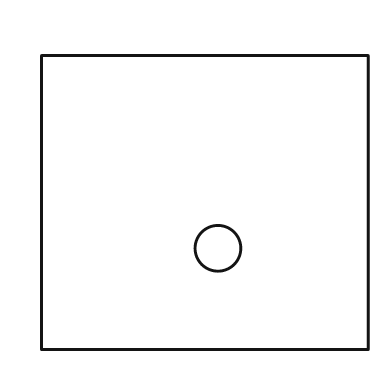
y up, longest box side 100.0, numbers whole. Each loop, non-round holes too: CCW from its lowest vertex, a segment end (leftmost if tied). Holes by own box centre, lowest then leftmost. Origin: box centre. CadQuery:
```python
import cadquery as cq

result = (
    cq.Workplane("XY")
    .moveTo(-50.0, -45.0)
    .lineTo(50.0, -45.0)
    .lineTo(50.0, 45.0)
    .lineTo(-50.0, 45.0)
    .close()
    .moveTo(4.0, -14.0)
    .circle(7.0)
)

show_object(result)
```